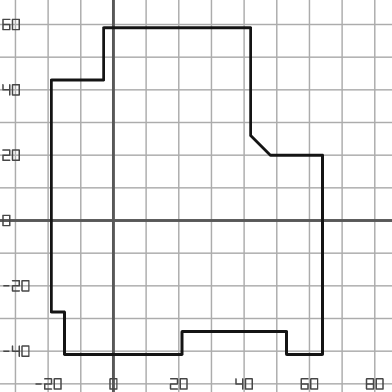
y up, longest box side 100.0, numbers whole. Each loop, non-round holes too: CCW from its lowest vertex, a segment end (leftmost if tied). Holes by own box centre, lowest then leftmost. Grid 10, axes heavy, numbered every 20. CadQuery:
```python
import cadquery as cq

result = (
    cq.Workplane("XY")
    .moveTo(-15.0, -41.0)
    .lineTo(21.0, -41.0)
    .lineTo(21.0, -34.0)
    .lineTo(53.0, -34.0)
    .lineTo(53.0, -41.0)
    .lineTo(64.0, -41.0)
    .lineTo(64.0, 20.0)
    .lineTo(48.0, 20.0)
    .lineTo(42.0, 26.0)
    .lineTo(42.0, 59.0)
    .lineTo(-3.0, 59.0)
    .lineTo(-3.0, 43.0)
    .lineTo(-19.0, 43.0)
    .lineTo(-19.0, -28.0)
    .lineTo(-15.0, -28.0)
    .close()
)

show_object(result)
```